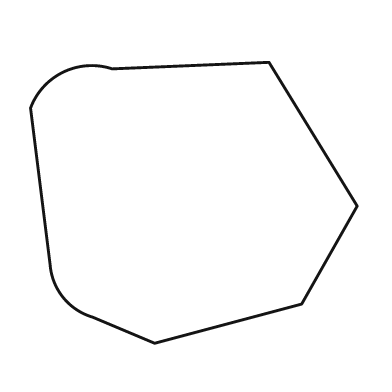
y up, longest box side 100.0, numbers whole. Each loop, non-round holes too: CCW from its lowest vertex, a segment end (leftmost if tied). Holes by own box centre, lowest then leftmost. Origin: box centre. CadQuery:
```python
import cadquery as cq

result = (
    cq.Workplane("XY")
    .moveTo(-12.0, -43.0)
    .lineTo(33.0, -31.0)
    .lineTo(50.0, -1.0)
    .lineTo(23.0, 43.0)
    .lineTo(-25.0, 41.0)
    .threePointArc((-40.0, 40.0), (-50.0, 29.0))
    .lineTo(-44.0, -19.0)
    .threePointArc((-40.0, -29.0), (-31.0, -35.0))
    .close()
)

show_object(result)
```